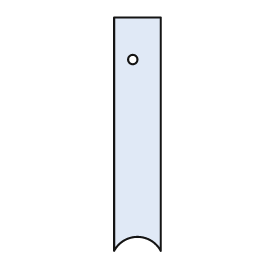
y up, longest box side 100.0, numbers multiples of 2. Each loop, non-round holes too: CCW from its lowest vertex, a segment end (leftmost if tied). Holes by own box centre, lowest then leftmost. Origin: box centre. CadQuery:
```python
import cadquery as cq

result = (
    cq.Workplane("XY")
    .moveTo(-10.0, -50.0)
    .threePointArc((0.0, -44.0), (10.0, -50.0))
    .lineTo(10.0, 50.0)
    .lineTo(-10.0, 50.0)
    .close()
    .moveTo(-2.0, 32.0)
    .circle(2.0)
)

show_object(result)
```